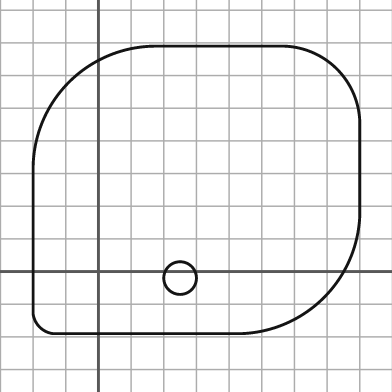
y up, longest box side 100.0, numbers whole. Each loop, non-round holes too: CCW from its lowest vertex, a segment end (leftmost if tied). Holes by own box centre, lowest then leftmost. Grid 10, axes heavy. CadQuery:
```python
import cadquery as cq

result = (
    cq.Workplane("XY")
    .moveTo(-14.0, -19.0)
    .lineTo(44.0, -19.0)
    .threePointArc((69.0, -8.0), (80.0, 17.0))
    .lineTo(80.0, 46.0)
    .threePointArc((73.0, 62.0), (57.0, 69.0))
    .lineTo(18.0, 69.0)
    .threePointArc((-9.0, 58.0), (-20.0, 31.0))
    .lineTo(-20.0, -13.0)
    .threePointArc((-18.0, -17.0), (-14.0, -19.0))
    .close()
    .moveTo(25.0, -2.0)
    .circle(5.0)
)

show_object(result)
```